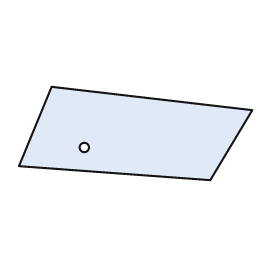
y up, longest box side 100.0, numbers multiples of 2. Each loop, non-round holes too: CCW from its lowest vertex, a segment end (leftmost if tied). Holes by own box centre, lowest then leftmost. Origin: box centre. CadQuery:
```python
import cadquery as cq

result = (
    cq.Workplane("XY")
    .moveTo(32.0, -20.0)
    .lineTo(50.0, 10.0)
    .lineTo(-36.0, 20.0)
    .lineTo(-50.0, -14.0)
    .close()
    .moveTo(-22.0, -6.0)
    .circle(2.0)
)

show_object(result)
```